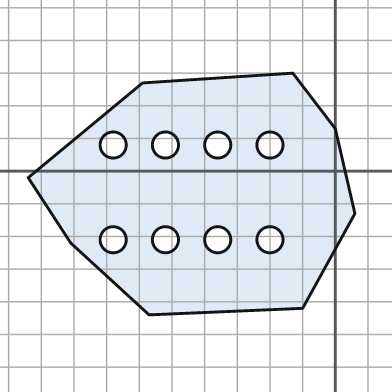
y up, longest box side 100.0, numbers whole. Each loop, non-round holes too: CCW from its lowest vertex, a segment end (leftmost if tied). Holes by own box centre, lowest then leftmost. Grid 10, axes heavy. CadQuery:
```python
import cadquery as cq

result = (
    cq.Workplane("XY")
    .moveTo(-57.0, -44.0)
    .lineTo(-10.0, -42.0)
    .lineTo(6.0, -13.0)
    .lineTo(0.0, 13.0)
    .lineTo(-13.0, 30.0)
    .lineTo(-59.0, 27.0)
    .lineTo(-94.0, -2.0)
    .lineTo(-81.0, -22.0)
    .close()
    .moveTo(-68.0, -21.0)
    .circle(4.0)
    .moveTo(-52.0, -21.0)
    .circle(4.0)
    .moveTo(-36.0, -21.0)
    .circle(4.0)
    .moveTo(-20.0, -21.0)
    .circle(4.0)
    .moveTo(-68.0, 8.0)
    .circle(4.0)
    .moveTo(-52.0, 8.0)
    .circle(4.0)
    .moveTo(-36.0, 8.0)
    .circle(4.0)
    .moveTo(-20.0, 8.0)
    .circle(4.0)
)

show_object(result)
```